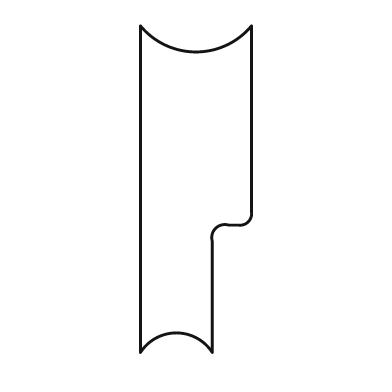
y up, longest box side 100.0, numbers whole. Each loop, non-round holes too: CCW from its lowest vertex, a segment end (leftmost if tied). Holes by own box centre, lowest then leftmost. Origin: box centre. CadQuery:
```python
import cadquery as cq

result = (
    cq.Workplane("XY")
    .moveTo(-17.0, -50.0)
    .threePointArc((-6.0, -44.0), (5.0, -50.0))
    .lineTo(5.0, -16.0)
    .threePointArc((6.0, -12.0), (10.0, -11.0))
    .lineTo(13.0, -11.0)
    .threePointArc((16.0, -10.0), (17.0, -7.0))
    .lineTo(17.0, 50.0)
    .threePointArc((0.0, 42.0), (-17.0, 50.0))
    .close()
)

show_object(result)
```